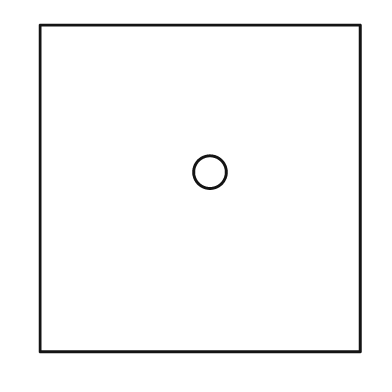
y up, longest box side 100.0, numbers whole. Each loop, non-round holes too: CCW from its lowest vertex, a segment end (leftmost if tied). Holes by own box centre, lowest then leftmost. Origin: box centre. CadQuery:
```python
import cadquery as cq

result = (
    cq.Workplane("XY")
    .moveTo(-49.0, -50.0)
    .lineTo(49.0, -50.0)
    .lineTo(49.0, 50.0)
    .lineTo(-49.0, 50.0)
    .close()
    .moveTo(3.0, 5.0)
    .circle(5.0)
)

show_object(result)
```